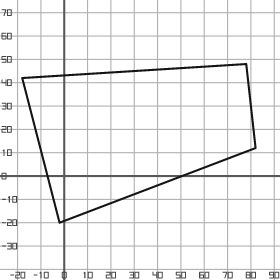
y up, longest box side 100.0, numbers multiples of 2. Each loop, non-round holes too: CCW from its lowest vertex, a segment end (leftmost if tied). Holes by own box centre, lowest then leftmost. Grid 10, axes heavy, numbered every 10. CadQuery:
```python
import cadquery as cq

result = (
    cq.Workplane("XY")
    .moveTo(-2.0, -20.0)
    .lineTo(82.0, 12.0)
    .lineTo(78.0, 48.0)
    .lineTo(-18.0, 42.0)
    .close()
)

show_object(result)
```